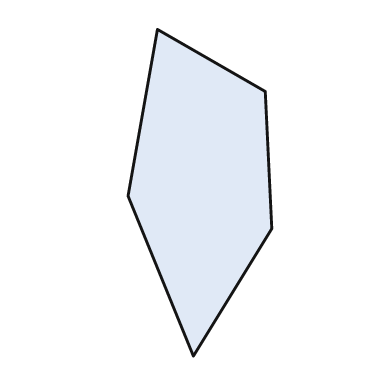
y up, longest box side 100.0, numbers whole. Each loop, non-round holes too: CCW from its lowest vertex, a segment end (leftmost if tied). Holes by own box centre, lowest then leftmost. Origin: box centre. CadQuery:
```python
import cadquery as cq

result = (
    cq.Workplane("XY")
    .moveTo(-2.0, -50.0)
    .lineTo(22.0, -11.0)
    .lineTo(20.0, 31.0)
    .lineTo(-13.0, 50.0)
    .lineTo(-22.0, -1.0)
    .close()
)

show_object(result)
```